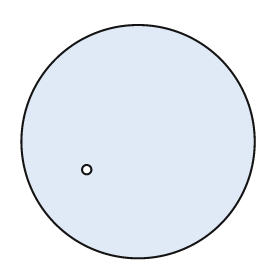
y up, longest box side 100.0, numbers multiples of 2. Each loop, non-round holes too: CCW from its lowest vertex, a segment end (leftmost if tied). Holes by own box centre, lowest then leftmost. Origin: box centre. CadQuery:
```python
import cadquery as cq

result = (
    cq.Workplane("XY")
    .moveTo(0.0, 0.0)
    .circle(50.0)
    .moveTo(-22.0, -12.0)
    .circle(2.0)
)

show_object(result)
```